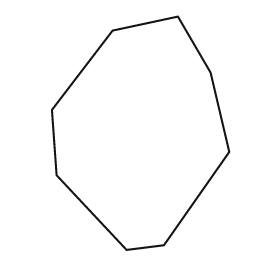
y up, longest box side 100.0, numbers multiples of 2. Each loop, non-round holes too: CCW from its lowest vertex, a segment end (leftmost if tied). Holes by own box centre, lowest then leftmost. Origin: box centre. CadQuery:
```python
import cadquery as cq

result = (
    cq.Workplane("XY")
    .moveTo(-6.0, -50.0)
    .lineTo(10.0, -48.0)
    .lineTo(38.0, -8.0)
    .lineTo(30.0, 26.0)
    .lineTo(16.0, 50.0)
    .lineTo(-12.0, 44.0)
    .lineTo(-38.0, 10.0)
    .lineTo(-36.0, -18.0)
    .close()
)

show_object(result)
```